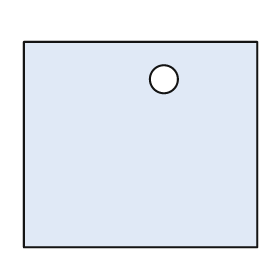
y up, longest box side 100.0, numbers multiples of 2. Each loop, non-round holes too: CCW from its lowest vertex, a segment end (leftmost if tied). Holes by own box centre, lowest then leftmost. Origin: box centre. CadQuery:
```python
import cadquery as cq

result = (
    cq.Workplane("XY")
    .moveTo(-50.0, -44.0)
    .lineTo(50.0, -44.0)
    .lineTo(50.0, 44.0)
    .lineTo(-50.0, 44.0)
    .close()
    .moveTo(10.0, 28.0)
    .circle(6.0)
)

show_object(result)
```